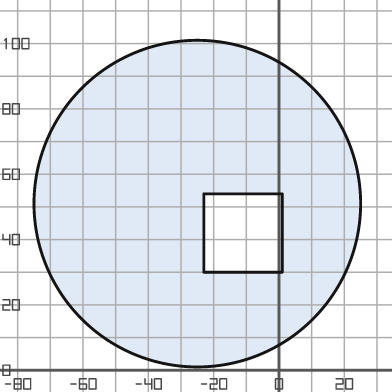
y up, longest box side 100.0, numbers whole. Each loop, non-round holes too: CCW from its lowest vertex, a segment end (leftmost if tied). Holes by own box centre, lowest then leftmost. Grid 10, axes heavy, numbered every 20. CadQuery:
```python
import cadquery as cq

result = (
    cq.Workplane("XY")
    .moveTo(-25.0, 51.0)
    .circle(50.0)
    .moveTo(-23.0, 30.0)
    .lineTo(1.0, 30.0)
    .lineTo(1.0, 54.0)
    .lineTo(-23.0, 54.0)
    .close()
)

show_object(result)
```